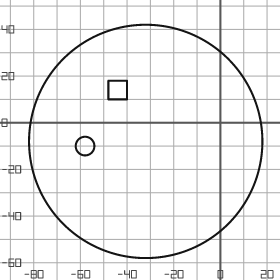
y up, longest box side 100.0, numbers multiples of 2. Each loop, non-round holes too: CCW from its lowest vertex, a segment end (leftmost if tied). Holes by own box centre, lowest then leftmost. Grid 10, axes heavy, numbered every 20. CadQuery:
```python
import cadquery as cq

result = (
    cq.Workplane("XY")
    .moveTo(-32.0, -8.0)
    .circle(50.0)
    .moveTo(-58.0, -10.0)
    .circle(4.0)
    .moveTo(-48.0, 10.0)
    .lineTo(-40.0, 10.0)
    .lineTo(-40.0, 18.0)
    .lineTo(-48.0, 18.0)
    .close()
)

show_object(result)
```